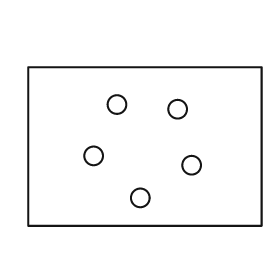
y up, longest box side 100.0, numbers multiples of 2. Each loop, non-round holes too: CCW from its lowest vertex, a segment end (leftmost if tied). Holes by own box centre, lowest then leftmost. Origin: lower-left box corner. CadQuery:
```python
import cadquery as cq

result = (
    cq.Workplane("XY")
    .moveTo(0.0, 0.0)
    .lineTo(100.0, 0.0)
    .lineTo(100.0, 68.0)
    .lineTo(0.0, 68.0)
    .close()
    .moveTo(48.0, 12.0)
    .circle(4.0)
    .moveTo(70.0, 26.0)
    .circle(4.0)
    .moveTo(28.0, 30.0)
    .circle(4.0)
    .moveTo(64.0, 50.0)
    .circle(4.0)
    .moveTo(38.0, 52.0)
    .circle(4.0)
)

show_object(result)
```